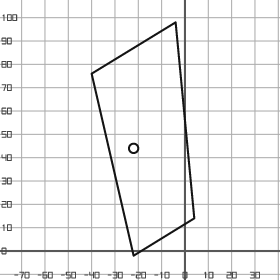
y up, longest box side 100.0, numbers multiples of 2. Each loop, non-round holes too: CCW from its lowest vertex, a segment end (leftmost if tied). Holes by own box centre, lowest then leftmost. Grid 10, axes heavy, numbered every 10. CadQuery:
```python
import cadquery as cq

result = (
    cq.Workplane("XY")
    .moveTo(-22.0, -2.0)
    .lineTo(4.0, 14.0)
    .lineTo(-4.0, 98.0)
    .lineTo(-40.0, 76.0)
    .close()
    .moveTo(-22.0, 44.0)
    .circle(2.0)
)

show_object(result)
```